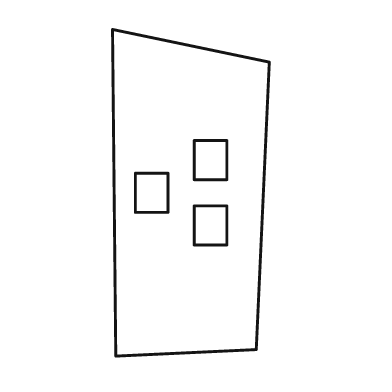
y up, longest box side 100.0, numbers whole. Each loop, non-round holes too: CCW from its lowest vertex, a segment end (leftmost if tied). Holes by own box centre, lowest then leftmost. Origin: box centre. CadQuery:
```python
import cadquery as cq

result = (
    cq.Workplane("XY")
    .moveTo(-23.0, -50.0)
    .lineTo(20.0, -48.0)
    .lineTo(24.0, 40.0)
    .lineTo(-24.0, 50.0)
    .close()
    .moveTo(1.0, -16.0)
    .lineTo(11.0, -16.0)
    .lineTo(11.0, -4.0)
    .lineTo(1.0, -4.0)
    .close()
    .moveTo(-17.0, -6.0)
    .lineTo(-7.0, -6.0)
    .lineTo(-7.0, 6.0)
    .lineTo(-17.0, 6.0)
    .close()
    .moveTo(1.0, 4.0)
    .lineTo(11.0, 4.0)
    .lineTo(11.0, 16.0)
    .lineTo(1.0, 16.0)
    .close()
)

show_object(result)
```